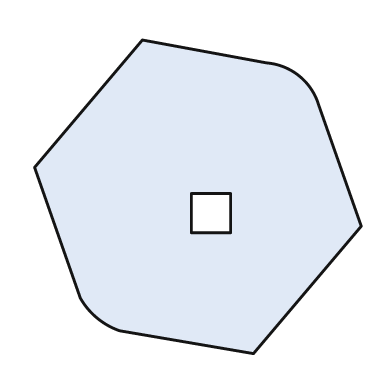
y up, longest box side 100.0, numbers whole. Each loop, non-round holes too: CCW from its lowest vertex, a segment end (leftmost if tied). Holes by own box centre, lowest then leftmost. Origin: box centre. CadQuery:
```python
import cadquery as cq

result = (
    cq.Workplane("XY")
    .moveTo(17.0, -48.0)
    .lineTo(50.0, -9.0)
    .lineTo(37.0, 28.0)
    .threePointArc((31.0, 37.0), (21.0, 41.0))
    .lineTo(-17.0, 48.0)
    .lineTo(-50.0, 9.0)
    .lineTo(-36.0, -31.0)
    .threePointArc((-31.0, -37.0), (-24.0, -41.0))
    .close()
    .moveTo(-2.0, -11.0)
    .lineTo(10.0, -11.0)
    .lineTo(10.0, 1.0)
    .lineTo(-2.0, 1.0)
    .close()
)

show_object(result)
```